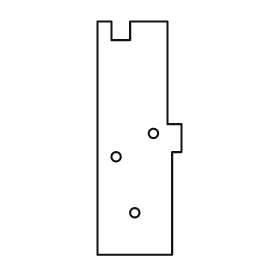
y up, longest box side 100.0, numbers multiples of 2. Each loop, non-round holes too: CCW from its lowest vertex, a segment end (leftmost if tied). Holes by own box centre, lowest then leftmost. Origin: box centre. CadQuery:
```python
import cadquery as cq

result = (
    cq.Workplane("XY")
    .moveTo(-18.0, -50.0)
    .lineTo(14.0, -50.0)
    .lineTo(14.0, -6.0)
    .lineTo(18.0, -6.0)
    .lineTo(18.0, 6.0)
    .lineTo(12.0, 6.0)
    .lineTo(12.0, 50.0)
    .lineTo(-4.0, 50.0)
    .lineTo(-4.0, 42.0)
    .lineTo(-12.0, 42.0)
    .lineTo(-12.0, 50.0)
    .lineTo(-18.0, 50.0)
    .close()
    .moveTo(-2.0, -32.0)
    .circle(2.0)
    .moveTo(-10.0, -8.0)
    .circle(2.0)
    .moveTo(6.0, 2.0)
    .circle(2.0)
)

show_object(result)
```